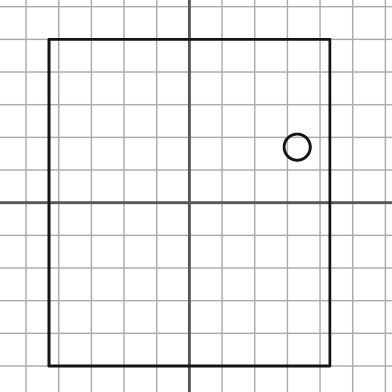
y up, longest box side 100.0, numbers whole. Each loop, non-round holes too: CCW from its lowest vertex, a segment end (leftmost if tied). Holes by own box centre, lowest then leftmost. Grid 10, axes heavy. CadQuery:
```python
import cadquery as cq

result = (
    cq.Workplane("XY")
    .moveTo(-43.0, -50.0)
    .lineTo(43.0, -50.0)
    .lineTo(43.0, 50.0)
    .lineTo(-43.0, 50.0)
    .close()
    .moveTo(33.0, 17.0)
    .circle(4.0)
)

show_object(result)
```